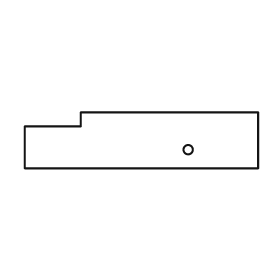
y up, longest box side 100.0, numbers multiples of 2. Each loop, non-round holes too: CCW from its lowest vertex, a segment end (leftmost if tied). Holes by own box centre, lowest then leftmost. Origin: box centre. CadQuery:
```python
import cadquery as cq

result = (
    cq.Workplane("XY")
    .moveTo(-50.0, -12.0)
    .lineTo(50.0, -12.0)
    .lineTo(50.0, 12.0)
    .lineTo(-26.0, 12.0)
    .lineTo(-26.0, 6.0)
    .lineTo(-50.0, 6.0)
    .close()
    .moveTo(20.0, -4.0)
    .circle(2.0)
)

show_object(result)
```